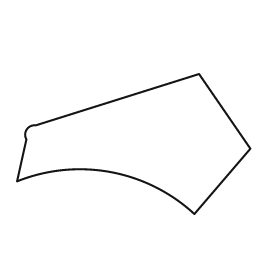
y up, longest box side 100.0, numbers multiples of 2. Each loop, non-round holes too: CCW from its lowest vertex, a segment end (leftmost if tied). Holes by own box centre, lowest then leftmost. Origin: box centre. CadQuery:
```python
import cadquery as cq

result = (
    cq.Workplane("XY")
    .moveTo(26.0, -30.0)
    .lineTo(50.0, -2.0)
    .lineTo(28.0, 30.0)
    .lineTo(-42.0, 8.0)
    .threePointArc((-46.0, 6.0), (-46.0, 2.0))
    .lineTo(-50.0, -16.0)
    .threePointArc((-10.0, -12.0), (26.0, -30.0))
    .close()
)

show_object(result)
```